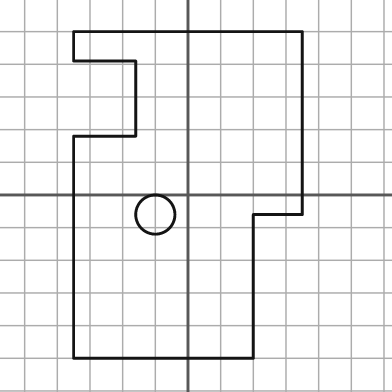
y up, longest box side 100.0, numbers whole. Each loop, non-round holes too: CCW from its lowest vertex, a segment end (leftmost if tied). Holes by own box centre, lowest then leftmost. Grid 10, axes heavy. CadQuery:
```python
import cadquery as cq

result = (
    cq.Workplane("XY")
    .moveTo(-35.0, -50.0)
    .lineTo(20.0, -50.0)
    .lineTo(20.0, -6.0)
    .lineTo(35.0, -6.0)
    .lineTo(35.0, 50.0)
    .lineTo(-35.0, 50.0)
    .lineTo(-35.0, 41.0)
    .lineTo(-16.0, 41.0)
    .lineTo(-16.0, 18.0)
    .lineTo(-35.0, 18.0)
    .close()
    .moveTo(-10.0, -6.0)
    .circle(6.0)
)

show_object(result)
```